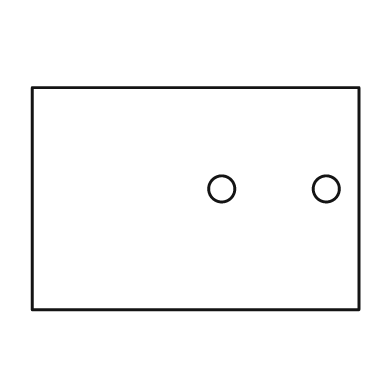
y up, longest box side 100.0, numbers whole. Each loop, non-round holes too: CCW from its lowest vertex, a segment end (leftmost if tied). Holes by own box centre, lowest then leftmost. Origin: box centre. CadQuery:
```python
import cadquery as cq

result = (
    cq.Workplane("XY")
    .moveTo(-50.0, -34.0)
    .lineTo(50.0, -34.0)
    .lineTo(50.0, 34.0)
    .lineTo(-50.0, 34.0)
    .close()
    .moveTo(8.0, 3.0)
    .circle(4.0)
    .moveTo(40.0, 3.0)
    .circle(4.0)
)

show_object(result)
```